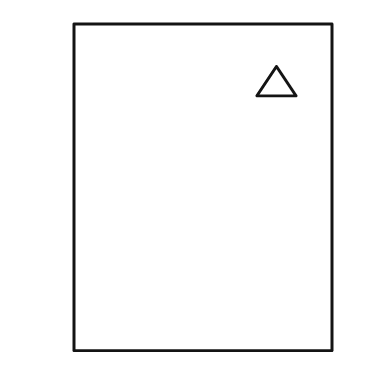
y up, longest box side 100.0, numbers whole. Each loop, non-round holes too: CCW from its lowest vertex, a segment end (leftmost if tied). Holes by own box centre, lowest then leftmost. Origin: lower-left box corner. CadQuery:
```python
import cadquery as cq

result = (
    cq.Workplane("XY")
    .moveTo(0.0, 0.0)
    .lineTo(79.0, 0.0)
    .lineTo(79.0, 100.0)
    .lineTo(0.0, 100.0)
    .close()
    .moveTo(56.0, 78.0)
    .lineTo(68.0, 78.0)
    .lineTo(62.0, 87.0)
    .close()
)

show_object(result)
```